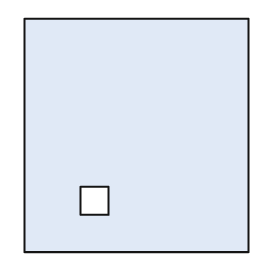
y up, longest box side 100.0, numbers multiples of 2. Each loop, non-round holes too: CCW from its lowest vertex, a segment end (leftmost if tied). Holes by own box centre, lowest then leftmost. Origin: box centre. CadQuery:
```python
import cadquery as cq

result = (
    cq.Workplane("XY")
    .moveTo(-48.0, -50.0)
    .lineTo(48.0, -50.0)
    .lineTo(48.0, 50.0)
    .lineTo(-48.0, 50.0)
    .close()
    .moveTo(-24.0, -34.0)
    .lineTo(-12.0, -34.0)
    .lineTo(-12.0, -22.0)
    .lineTo(-24.0, -22.0)
    .close()
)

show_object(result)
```